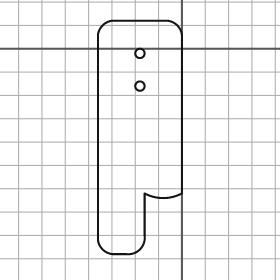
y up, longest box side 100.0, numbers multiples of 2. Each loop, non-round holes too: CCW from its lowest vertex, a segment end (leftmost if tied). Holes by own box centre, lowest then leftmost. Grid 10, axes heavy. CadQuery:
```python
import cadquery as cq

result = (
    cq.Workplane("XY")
    .moveTo(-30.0, -88.0)
    .lineTo(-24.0, -88.0)
    .threePointArc((-18.0, -86.0), (-16.0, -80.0))
    .lineTo(-16.0, -62.0)
    .threePointArc((-8.0, -64.0), (0.0, -62.0))
    .lineTo(0.0, 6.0)
    .threePointArc((-2.0, 10.0), (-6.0, 12.0))
    .lineTo(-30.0, 12.0)
    .threePointArc((-34.0, 10.0), (-36.0, 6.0))
    .lineTo(-36.0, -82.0)
    .threePointArc((-34.0, -86.0), (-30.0, -88.0))
    .close()
    .moveTo(-18.0, -16.0)
    .circle(2.0)
    .moveTo(-18.0, -2.0)
    .circle(2.0)
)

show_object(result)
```